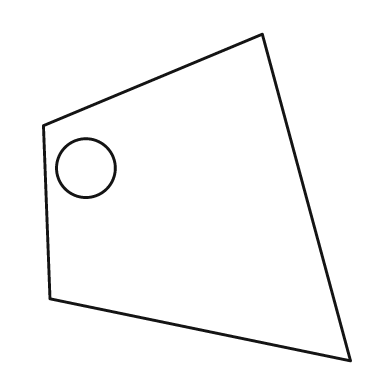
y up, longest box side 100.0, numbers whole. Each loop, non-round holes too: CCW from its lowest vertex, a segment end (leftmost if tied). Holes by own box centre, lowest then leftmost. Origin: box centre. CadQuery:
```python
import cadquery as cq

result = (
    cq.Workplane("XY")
    .moveTo(47.0, -50.0)
    .lineTo(20.0, 50.0)
    .lineTo(-47.0, 22.0)
    .lineTo(-45.0, -31.0)
    .close()
    .moveTo(-34.0, 9.0)
    .circle(9.0)
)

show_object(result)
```